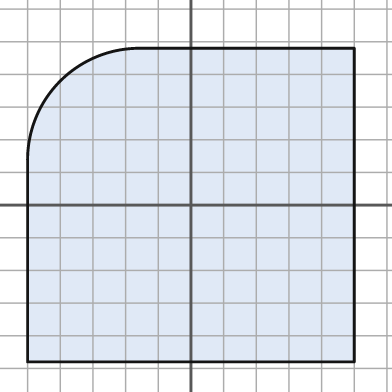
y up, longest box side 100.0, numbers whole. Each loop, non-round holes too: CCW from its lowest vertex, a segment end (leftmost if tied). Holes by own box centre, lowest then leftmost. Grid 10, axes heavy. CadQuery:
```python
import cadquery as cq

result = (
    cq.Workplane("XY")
    .moveTo(-50.0, -48.0)
    .lineTo(50.0, -48.0)
    .lineTo(50.0, 48.0)
    .lineTo(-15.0, 48.0)
    .threePointArc((-40.0, 38.0), (-50.0, 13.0))
    .close()
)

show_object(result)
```